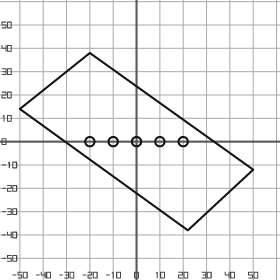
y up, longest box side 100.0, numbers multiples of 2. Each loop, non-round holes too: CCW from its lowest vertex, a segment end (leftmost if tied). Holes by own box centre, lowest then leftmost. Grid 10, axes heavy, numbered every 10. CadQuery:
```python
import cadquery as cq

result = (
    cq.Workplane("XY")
    .moveTo(22.0, -38.0)
    .lineTo(50.0, -12.0)
    .lineTo(-20.0, 38.0)
    .lineTo(-50.0, 14.0)
    .close()
    .moveTo(-20.0, 0.0)
    .circle(2.0)
    .moveTo(-10.0, 0.0)
    .circle(2.0)
    .moveTo(0.0, 0.0)
    .circle(2.0)
    .moveTo(10.0, 0.0)
    .circle(2.0)
    .moveTo(20.0, 0.0)
    .circle(2.0)
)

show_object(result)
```